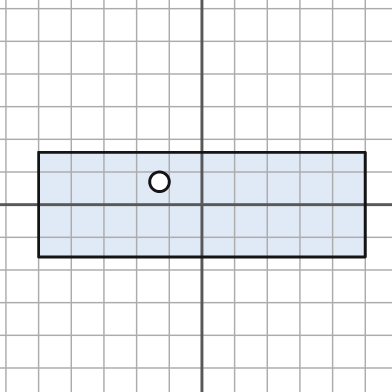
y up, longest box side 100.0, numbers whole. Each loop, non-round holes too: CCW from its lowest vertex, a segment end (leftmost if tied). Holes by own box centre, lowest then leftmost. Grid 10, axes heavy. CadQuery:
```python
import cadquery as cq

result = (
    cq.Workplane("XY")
    .moveTo(-50.0, -16.0)
    .lineTo(50.0, -16.0)
    .lineTo(50.0, 16.0)
    .lineTo(-50.0, 16.0)
    .close()
    .moveTo(-13.0, 7.0)
    .circle(3.0)
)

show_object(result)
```